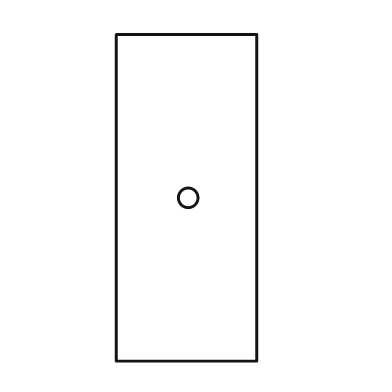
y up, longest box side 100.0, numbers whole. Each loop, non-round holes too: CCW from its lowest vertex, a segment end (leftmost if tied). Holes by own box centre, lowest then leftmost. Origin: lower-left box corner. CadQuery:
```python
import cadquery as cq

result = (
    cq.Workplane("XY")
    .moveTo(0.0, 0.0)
    .lineTo(43.0, 0.0)
    .lineTo(43.0, 100.0)
    .lineTo(0.0, 100.0)
    .close()
    .moveTo(22.0, 50.0)
    .circle(3.0)
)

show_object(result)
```